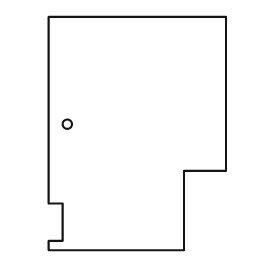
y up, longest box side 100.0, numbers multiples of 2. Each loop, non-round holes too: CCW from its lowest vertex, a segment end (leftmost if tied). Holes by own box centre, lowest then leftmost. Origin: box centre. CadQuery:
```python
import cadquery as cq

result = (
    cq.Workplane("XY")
    .moveTo(-38.0, -50.0)
    .lineTo(20.0, -50.0)
    .lineTo(20.0, -16.0)
    .lineTo(38.0, -16.0)
    .lineTo(38.0, 50.0)
    .lineTo(-38.0, 50.0)
    .lineTo(-38.0, -30.0)
    .lineTo(-32.0, -30.0)
    .lineTo(-32.0, -46.0)
    .lineTo(-38.0, -46.0)
    .close()
    .moveTo(-30.0, 4.0)
    .circle(2.0)
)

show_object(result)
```